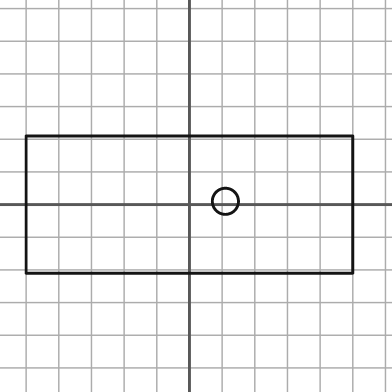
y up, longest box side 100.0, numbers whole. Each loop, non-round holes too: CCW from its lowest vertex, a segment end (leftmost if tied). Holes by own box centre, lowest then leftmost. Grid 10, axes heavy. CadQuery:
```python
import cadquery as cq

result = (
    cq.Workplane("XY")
    .moveTo(-50.0, -21.0)
    .lineTo(50.0, -21.0)
    .lineTo(50.0, 21.0)
    .lineTo(-50.0, 21.0)
    .close()
    .moveTo(11.0, 1.0)
    .circle(4.0)
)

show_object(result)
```